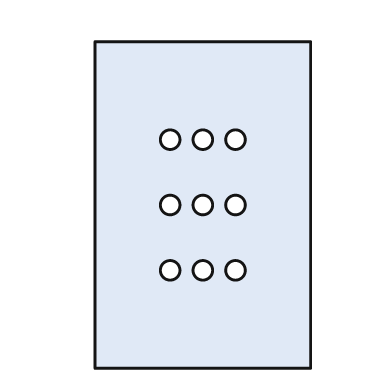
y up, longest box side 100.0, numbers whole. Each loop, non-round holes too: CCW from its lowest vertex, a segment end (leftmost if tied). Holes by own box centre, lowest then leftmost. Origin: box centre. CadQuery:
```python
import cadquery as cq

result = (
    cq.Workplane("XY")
    .moveTo(-33.0, -50.0)
    .lineTo(33.0, -50.0)
    .lineTo(33.0, 50.0)
    .lineTo(-33.0, 50.0)
    .close()
    .moveTo(-10.0, -20.0)
    .circle(3.0)
    .moveTo(0.0, -20.0)
    .circle(3.0)
    .moveTo(10.0, -20.0)
    .circle(3.0)
    .moveTo(-10.0, 0.0)
    .circle(3.0)
    .moveTo(0.0, 0.0)
    .circle(3.0)
    .moveTo(10.0, 0.0)
    .circle(3.0)
    .moveTo(-10.0, 20.0)
    .circle(3.0)
    .moveTo(0.0, 20.0)
    .circle(3.0)
    .moveTo(10.0, 20.0)
    .circle(3.0)
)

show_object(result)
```